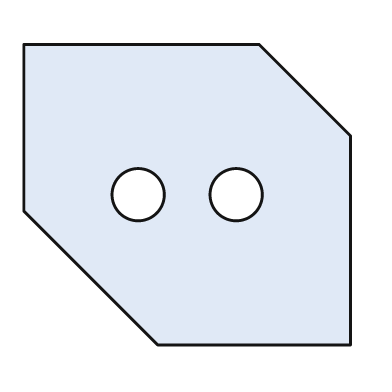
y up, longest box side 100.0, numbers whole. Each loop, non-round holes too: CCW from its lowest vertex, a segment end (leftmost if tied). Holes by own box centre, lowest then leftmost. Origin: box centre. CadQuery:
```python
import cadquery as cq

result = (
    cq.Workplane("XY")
    .moveTo(-9.0, -46.0)
    .lineTo(50.0, -46.0)
    .lineTo(50.0, 18.0)
    .lineTo(22.0, 46.0)
    .lineTo(-50.0, 46.0)
    .lineTo(-50.0, -5.0)
    .close()
    .moveTo(-15.0, 0.0)
    .circle(8.0)
    .moveTo(15.0, 0.0)
    .circle(8.0)
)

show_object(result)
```